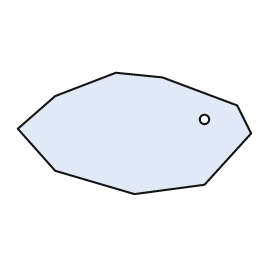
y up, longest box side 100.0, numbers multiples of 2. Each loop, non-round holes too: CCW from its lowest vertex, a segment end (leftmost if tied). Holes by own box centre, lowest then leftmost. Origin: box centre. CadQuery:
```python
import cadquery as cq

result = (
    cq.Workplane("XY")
    .moveTo(0.0, -26.0)
    .lineTo(30.0, -22.0)
    .lineTo(50.0, 0.0)
    .lineTo(44.0, 12.0)
    .lineTo(12.0, 24.0)
    .lineTo(-8.0, 26.0)
    .lineTo(-34.0, 16.0)
    .lineTo(-50.0, 2.0)
    .lineTo(-34.0, -16.0)
    .close()
    .moveTo(30.0, 6.0)
    .circle(2.0)
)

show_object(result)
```